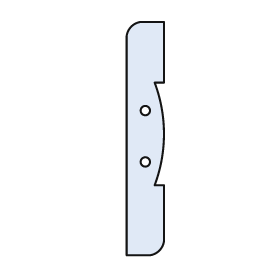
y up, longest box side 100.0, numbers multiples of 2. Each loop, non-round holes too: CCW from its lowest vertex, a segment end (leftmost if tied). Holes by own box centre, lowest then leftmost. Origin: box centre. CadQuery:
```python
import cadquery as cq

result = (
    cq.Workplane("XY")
    .moveTo(-8.0, -50.0)
    .lineTo(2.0, -50.0)
    .threePointArc((6.0, -48.0), (8.0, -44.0))
    .lineTo(8.0, -20.0)
    .lineTo(4.0, -20.0)
    .threePointArc((8.0, 2.0), (4.0, 24.0))
    .lineTo(8.0, 24.0)
    .lineTo(8.0, 50.0)
    .lineTo(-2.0, 50.0)
    .threePointArc((-6.0, 48.0), (-8.0, 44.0))
    .close()
    .moveTo(0.0, -10.0)
    .circle(2.0)
    .moveTo(0.0, 12.0)
    .circle(2.0)
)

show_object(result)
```